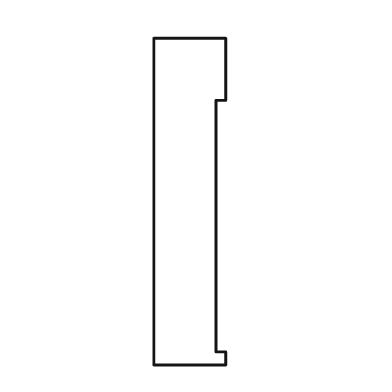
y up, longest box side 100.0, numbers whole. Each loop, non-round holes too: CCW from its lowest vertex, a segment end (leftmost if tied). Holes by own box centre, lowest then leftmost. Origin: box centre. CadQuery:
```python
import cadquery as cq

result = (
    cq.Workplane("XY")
    .moveTo(-11.0, -50.0)
    .lineTo(11.0, -50.0)
    .lineTo(11.0, -46.0)
    .lineTo(8.0, -46.0)
    .lineTo(8.0, 31.0)
    .lineTo(11.0, 31.0)
    .lineTo(11.0, 50.0)
    .lineTo(-11.0, 50.0)
    .close()
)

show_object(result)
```